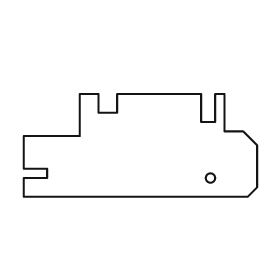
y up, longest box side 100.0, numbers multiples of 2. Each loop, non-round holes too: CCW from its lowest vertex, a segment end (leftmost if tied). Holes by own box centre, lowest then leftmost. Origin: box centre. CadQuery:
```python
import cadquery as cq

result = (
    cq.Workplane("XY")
    .moveTo(-50.0, -22.0)
    .lineTo(46.0, -22.0)
    .lineTo(50.0, -18.0)
    .lineTo(50.0, 0.0)
    .lineTo(44.0, 6.0)
    .lineTo(36.0, 6.0)
    .lineTo(36.0, 22.0)
    .lineTo(32.0, 22.0)
    .lineTo(32.0, 10.0)
    .lineTo(26.0, 10.0)
    .lineTo(26.0, 22.0)
    .lineTo(-10.0, 22.0)
    .lineTo(-10.0, 14.0)
    .lineTo(-18.0, 14.0)
    .lineTo(-18.0, 22.0)
    .lineTo(-26.0, 22.0)
    .lineTo(-26.0, 4.0)
    .lineTo(-50.0, 4.0)
    .lineTo(-50.0, -10.0)
    .lineTo(-40.0, -10.0)
    .lineTo(-40.0, -14.0)
    .lineTo(-50.0, -14.0)
    .close()
    .moveTo(30.0, -14.0)
    .circle(2.0)
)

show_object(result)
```